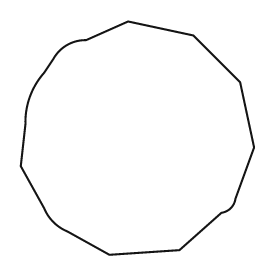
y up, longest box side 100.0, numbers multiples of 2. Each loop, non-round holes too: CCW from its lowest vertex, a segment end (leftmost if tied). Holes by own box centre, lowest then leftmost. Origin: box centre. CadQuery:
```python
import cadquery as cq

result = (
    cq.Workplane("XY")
    .moveTo(-12.0, -50.0)
    .lineTo(18.0, -48.0)
    .lineTo(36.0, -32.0)
    .threePointArc((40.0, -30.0), (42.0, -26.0))
    .lineTo(50.0, -4.0)
    .lineTo(44.0, 24.0)
    .lineTo(24.0, 44.0)
    .lineTo(-4.0, 50.0)
    .lineTo(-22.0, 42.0)
    .threePointArc((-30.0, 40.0), (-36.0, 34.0))
    .lineTo(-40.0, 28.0)
    .threePointArc((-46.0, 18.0), (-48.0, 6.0))
    .lineTo(-50.0, -12.0)
    .lineTo(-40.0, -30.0)
    .threePointArc((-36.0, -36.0), (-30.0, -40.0))
    .close()
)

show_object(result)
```